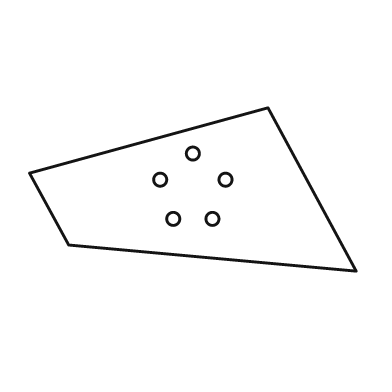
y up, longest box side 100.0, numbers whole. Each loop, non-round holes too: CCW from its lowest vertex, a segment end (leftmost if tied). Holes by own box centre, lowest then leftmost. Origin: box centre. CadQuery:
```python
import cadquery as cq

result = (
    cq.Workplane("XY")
    .moveTo(50.0, -25.0)
    .lineTo(23.0, 25.0)
    .lineTo(-50.0, 5.0)
    .lineTo(-38.0, -17.0)
    .close()
    .moveTo(-6.0, -9.0)
    .circle(2.0)
    .moveTo(6.0, -9.0)
    .circle(2.0)
    .moveTo(-10.0, 3.0)
    .circle(2.0)
    .moveTo(10.0, 3.0)
    .circle(2.0)
    .moveTo(0.0, 11.0)
    .circle(2.0)
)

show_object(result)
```